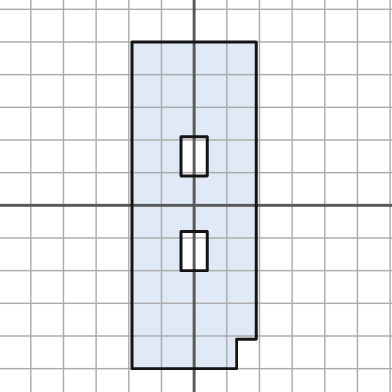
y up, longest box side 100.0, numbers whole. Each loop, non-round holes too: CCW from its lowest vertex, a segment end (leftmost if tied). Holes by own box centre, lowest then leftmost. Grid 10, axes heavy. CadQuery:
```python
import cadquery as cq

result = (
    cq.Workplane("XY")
    .moveTo(-19.0, -50.0)
    .lineTo(13.0, -50.0)
    .lineTo(13.0, -41.0)
    .lineTo(19.0, -41.0)
    .lineTo(19.0, 50.0)
    .lineTo(-19.0, 50.0)
    .close()
    .moveTo(-4.0, -20.0)
    .lineTo(4.0, -20.0)
    .lineTo(4.0, -8.0)
    .lineTo(-4.0, -8.0)
    .close()
    .moveTo(-4.0, 9.0)
    .lineTo(4.0, 9.0)
    .lineTo(4.0, 21.0)
    .lineTo(-4.0, 21.0)
    .close()
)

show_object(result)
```